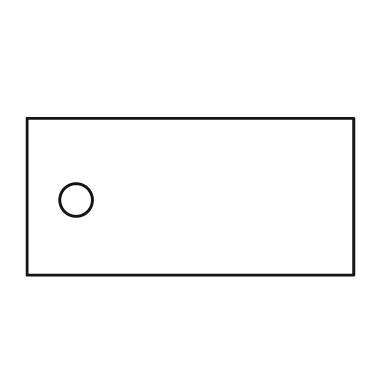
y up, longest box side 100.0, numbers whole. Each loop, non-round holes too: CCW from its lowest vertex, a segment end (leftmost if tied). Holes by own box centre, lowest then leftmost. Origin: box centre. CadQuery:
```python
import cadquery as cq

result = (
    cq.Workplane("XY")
    .moveTo(-50.0, -24.0)
    .lineTo(50.0, -24.0)
    .lineTo(50.0, 24.0)
    .lineTo(-50.0, 24.0)
    .close()
    .moveTo(-35.0, -1.0)
    .circle(5.0)
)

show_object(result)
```